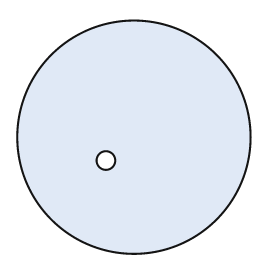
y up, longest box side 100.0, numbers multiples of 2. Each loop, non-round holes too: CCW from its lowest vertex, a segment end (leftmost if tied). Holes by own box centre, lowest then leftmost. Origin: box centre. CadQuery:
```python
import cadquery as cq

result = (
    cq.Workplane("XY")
    .moveTo(0.0, 0.0)
    .circle(50.0)
    .moveTo(-12.0, -10.0)
    .circle(4.0)
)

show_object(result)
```